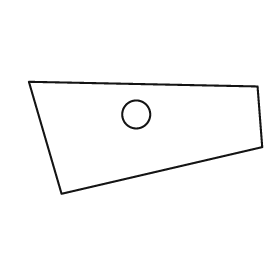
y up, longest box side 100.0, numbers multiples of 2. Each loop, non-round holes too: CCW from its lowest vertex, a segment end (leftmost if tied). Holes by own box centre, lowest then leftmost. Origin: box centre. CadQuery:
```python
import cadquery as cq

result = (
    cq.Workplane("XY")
    .moveTo(-36.0, -24.0)
    .lineTo(50.0, -4.0)
    .lineTo(48.0, 22.0)
    .lineTo(-50.0, 24.0)
    .close()
    .moveTo(-4.0, 10.0)
    .circle(6.0)
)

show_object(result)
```